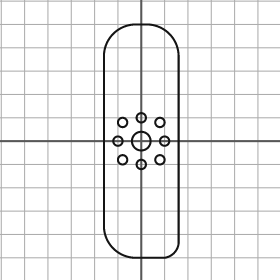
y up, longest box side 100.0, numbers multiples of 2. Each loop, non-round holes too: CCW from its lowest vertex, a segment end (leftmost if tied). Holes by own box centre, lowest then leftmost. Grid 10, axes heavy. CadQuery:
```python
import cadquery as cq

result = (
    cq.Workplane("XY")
    .moveTo(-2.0, -50.0)
    .lineTo(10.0, -50.0)
    .threePointArc((14.0, -48.0), (16.0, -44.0))
    .lineTo(16.0, 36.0)
    .threePointArc((12.0, 46.0), (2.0, 50.0))
    .lineTo(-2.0, 50.0)
    .threePointArc((-12.0, 46.0), (-16.0, 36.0))
    .lineTo(-16.0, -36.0)
    .threePointArc((-12.0, -46.0), (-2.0, -50.0))
    .close()
    .moveTo(0.0, -10.0)
    .circle(2.0)
    .moveTo(-8.0, -8.0)
    .circle(2.0)
    .moveTo(8.0, -8.0)
    .circle(2.0)
    .moveTo(-10.0, 0.0)
    .circle(2.0)
    .moveTo(0.0, 0.0)
    .circle(4.0)
    .moveTo(10.0, 0.0)
    .circle(2.0)
    .moveTo(-8.0, 8.0)
    .circle(2.0)
    .moveTo(8.0, 8.0)
    .circle(2.0)
    .moveTo(0.0, 10.0)
    .circle(2.0)
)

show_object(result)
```